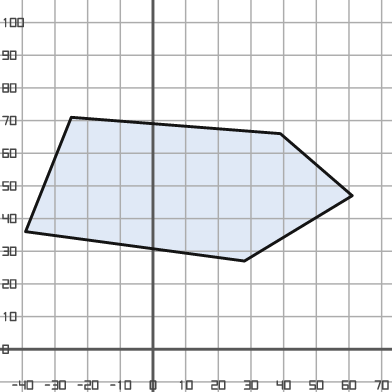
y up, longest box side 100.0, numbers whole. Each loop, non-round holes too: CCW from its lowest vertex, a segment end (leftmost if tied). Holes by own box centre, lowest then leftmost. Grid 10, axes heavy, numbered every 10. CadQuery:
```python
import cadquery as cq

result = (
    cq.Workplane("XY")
    .moveTo(28.0, 27.0)
    .lineTo(61.0, 47.0)
    .lineTo(39.0, 66.0)
    .lineTo(-25.0, 71.0)
    .lineTo(-39.0, 36.0)
    .close()
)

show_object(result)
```